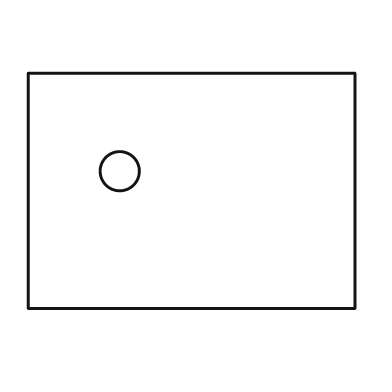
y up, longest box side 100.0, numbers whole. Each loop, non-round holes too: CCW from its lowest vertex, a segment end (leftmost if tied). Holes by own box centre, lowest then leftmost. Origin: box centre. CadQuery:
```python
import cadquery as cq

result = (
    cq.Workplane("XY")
    .moveTo(-50.0, -36.0)
    .lineTo(50.0, -36.0)
    .lineTo(50.0, 36.0)
    .lineTo(-50.0, 36.0)
    .close()
    .moveTo(-22.0, 6.0)
    .circle(6.0)
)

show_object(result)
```